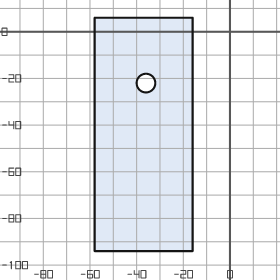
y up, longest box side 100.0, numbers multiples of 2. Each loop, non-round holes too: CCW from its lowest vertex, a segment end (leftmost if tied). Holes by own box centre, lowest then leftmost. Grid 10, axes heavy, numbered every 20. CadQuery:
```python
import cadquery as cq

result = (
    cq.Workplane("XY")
    .moveTo(-58.0, -94.0)
    .lineTo(-16.0, -94.0)
    .lineTo(-16.0, 6.0)
    .lineTo(-58.0, 6.0)
    .close()
    .moveTo(-36.0, -22.0)
    .circle(4.0)
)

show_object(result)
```